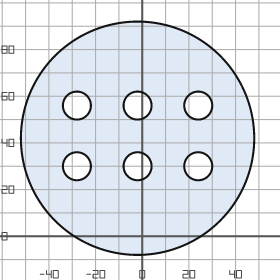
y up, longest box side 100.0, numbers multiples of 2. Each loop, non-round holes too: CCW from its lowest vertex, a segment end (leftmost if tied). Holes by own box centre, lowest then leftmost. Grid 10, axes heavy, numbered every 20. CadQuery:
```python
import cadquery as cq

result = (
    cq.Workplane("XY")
    .moveTo(-2.0, 42.0)
    .circle(50.0)
    .moveTo(-28.0, 30.0)
    .circle(6.0)
    .moveTo(-2.0, 30.0)
    .circle(6.0)
    .moveTo(24.0, 30.0)
    .circle(6.0)
    .moveTo(-28.0, 56.0)
    .circle(6.0)
    .moveTo(-2.0, 56.0)
    .circle(6.0)
    .moveTo(24.0, 56.0)
    .circle(6.0)
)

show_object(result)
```